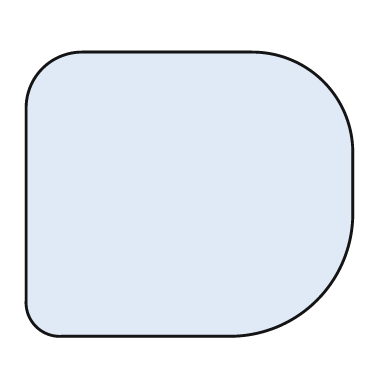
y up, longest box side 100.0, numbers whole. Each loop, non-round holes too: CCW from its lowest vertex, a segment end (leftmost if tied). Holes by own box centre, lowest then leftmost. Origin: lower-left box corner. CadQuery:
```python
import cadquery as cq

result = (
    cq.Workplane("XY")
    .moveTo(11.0, 0.0)
    .lineTo(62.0, 0.0)
    .threePointArc((89.0, 11.0), (100.0, 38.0))
    .lineTo(100.0, 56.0)
    .threePointArc((91.0, 78.0), (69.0, 87.0))
    .lineTo(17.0, 87.0)
    .threePointArc((5.0, 82.0), (0.0, 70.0))
    .lineTo(0.0, 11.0)
    .threePointArc((3.0, 3.0), (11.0, 0.0))
    .close()
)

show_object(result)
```